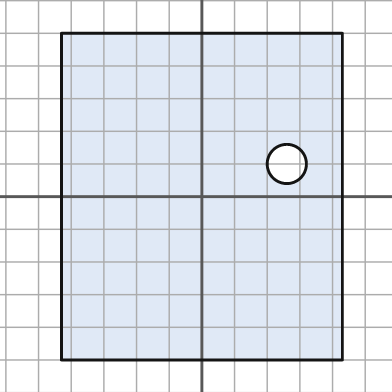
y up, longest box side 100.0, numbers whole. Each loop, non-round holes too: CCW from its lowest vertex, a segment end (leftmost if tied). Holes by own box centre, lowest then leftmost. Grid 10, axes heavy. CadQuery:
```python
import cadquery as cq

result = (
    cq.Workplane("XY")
    .moveTo(-43.0, -50.0)
    .lineTo(43.0, -50.0)
    .lineTo(43.0, 50.0)
    .lineTo(-43.0, 50.0)
    .close()
    .moveTo(26.0, 10.0)
    .circle(6.0)
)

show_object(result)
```